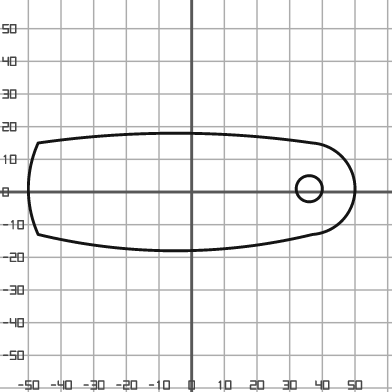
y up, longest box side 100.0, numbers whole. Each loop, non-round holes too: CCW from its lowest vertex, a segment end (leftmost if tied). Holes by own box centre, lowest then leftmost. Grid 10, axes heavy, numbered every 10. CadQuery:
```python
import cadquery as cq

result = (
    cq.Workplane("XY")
    .moveTo(-47.0, -13.0)
    .threePointArc((-5.0, -18.0), (37.0, -13.0))
    .threePointArc((50.0, 1.0), (37.0, 15.0))
    .threePointArc((-5.0, 18.0), (-47.0, 15.0))
    .threePointArc((-50.0, 1.0), (-47.0, -13.0))
    .close()
    .moveTo(36.0, 1.0)
    .circle(4.0)
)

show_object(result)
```